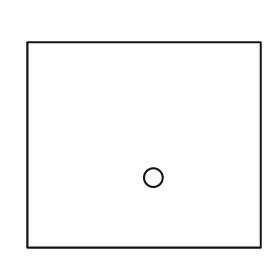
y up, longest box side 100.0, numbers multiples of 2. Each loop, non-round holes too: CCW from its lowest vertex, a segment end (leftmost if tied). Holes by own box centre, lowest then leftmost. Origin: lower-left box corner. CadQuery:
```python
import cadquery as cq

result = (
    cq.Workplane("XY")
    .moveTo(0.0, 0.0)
    .lineTo(100.0, 0.0)
    .lineTo(100.0, 88.0)
    .lineTo(0.0, 88.0)
    .close()
    .moveTo(54.0, 30.0)
    .circle(4.0)
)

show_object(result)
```